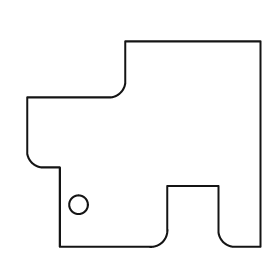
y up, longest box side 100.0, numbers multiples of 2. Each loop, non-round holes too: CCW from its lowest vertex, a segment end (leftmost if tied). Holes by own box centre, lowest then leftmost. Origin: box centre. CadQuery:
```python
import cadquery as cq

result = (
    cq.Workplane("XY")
    .moveTo(-36.0, -44.0)
    .lineTo(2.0, -44.0)
    .threePointArc((8.0, -42.0), (10.0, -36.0))
    .lineTo(10.0, -18.0)
    .lineTo(32.0, -18.0)
    .lineTo(32.0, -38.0)
    .threePointArc((34.0, -42.0), (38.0, -44.0))
    .lineTo(50.0, -44.0)
    .lineTo(50.0, 44.0)
    .lineTo(-8.0, 44.0)
    .lineTo(-8.0, 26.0)
    .threePointArc((-10.0, 22.0), (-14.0, 20.0))
    .lineTo(-50.0, 20.0)
    .lineTo(-50.0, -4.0)
    .threePointArc((-48.0, -8.0), (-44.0, -10.0))
    .lineTo(-36.0, -10.0)
    .close()
    .moveTo(-28.0, -26.0)
    .circle(4.0)
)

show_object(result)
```